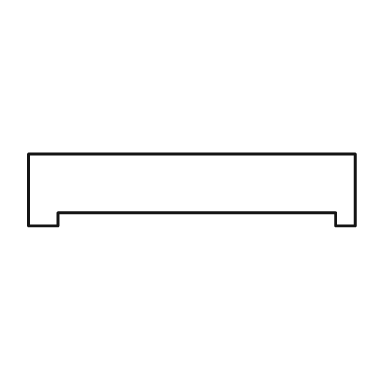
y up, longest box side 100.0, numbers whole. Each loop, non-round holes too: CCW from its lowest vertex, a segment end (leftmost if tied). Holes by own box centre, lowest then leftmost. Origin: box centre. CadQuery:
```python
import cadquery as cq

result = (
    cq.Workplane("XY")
    .moveTo(-50.0, -11.0)
    .lineTo(-41.0, -11.0)
    .lineTo(-41.0, -7.0)
    .lineTo(44.0, -7.0)
    .lineTo(44.0, -11.0)
    .lineTo(50.0, -11.0)
    .lineTo(50.0, 11.0)
    .lineTo(-50.0, 11.0)
    .close()
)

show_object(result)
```